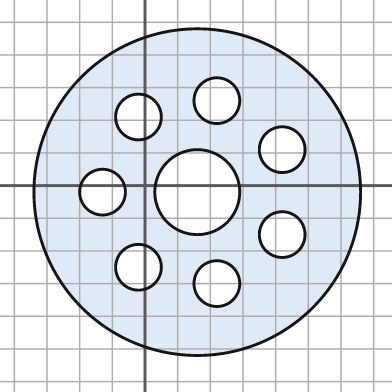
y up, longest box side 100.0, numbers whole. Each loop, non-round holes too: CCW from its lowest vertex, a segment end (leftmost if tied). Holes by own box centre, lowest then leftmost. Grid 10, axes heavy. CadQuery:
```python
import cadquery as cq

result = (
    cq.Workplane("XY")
    .moveTo(16.0, -2.0)
    .circle(50.0)
    .moveTo(22.0, -30.0)
    .circle(7.0)
    .moveTo(-2.0, -25.0)
    .circle(7.0)
    .moveTo(42.0, -15.0)
    .circle(7.0)
    .moveTo(-13.0, -2.0)
    .circle(7.0)
    .moveTo(16.0, -2.0)
    .circle(13.0)
    .moveTo(42.0, 11.0)
    .circle(7.0)
    .moveTo(-2.0, 21.0)
    .circle(7.0)
    .moveTo(22.0, 26.0)
    .circle(7.0)
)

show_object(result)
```